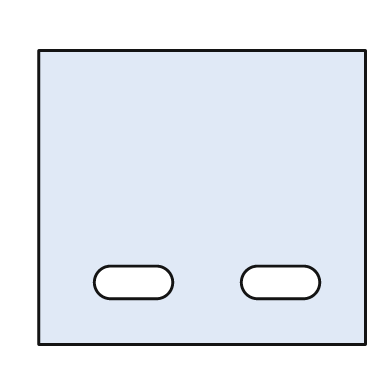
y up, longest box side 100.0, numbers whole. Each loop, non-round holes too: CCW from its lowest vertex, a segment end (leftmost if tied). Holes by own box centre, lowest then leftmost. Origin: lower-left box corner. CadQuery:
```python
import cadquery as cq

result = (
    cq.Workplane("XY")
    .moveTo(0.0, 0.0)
    .lineTo(100.0, 0.0)
    .lineTo(100.0, 90.0)
    .lineTo(0.0, 90.0)
    .close()
    .moveTo(22.0, 14.0)
    .lineTo(36.0, 14.0)
    .threePointArc((41.0, 19.0), (36.0, 24.0))
    .lineTo(22.0, 24.0)
    .threePointArc((17.0, 19.0), (22.0, 14.0))
    .close()
    .moveTo(67.0, 14.0)
    .lineTo(81.0, 14.0)
    .threePointArc((86.0, 19.0), (81.0, 24.0))
    .lineTo(67.0, 24.0)
    .threePointArc((62.0, 19.0), (67.0, 14.0))
    .close()
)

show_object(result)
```